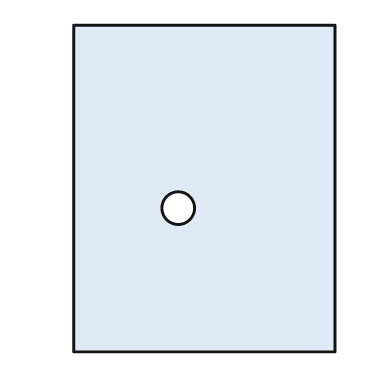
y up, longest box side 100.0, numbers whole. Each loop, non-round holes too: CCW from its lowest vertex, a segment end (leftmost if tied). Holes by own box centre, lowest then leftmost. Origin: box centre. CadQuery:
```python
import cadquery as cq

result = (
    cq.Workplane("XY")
    .moveTo(-40.0, -50.0)
    .lineTo(40.0, -50.0)
    .lineTo(40.0, 50.0)
    .lineTo(-40.0, 50.0)
    .close()
    .moveTo(-8.0, -6.0)
    .circle(5.0)
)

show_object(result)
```